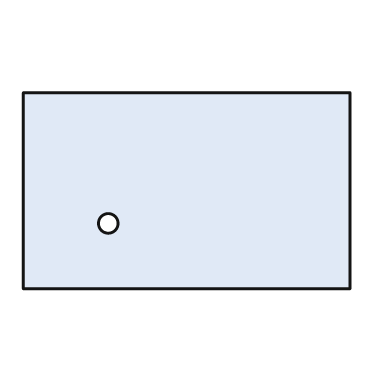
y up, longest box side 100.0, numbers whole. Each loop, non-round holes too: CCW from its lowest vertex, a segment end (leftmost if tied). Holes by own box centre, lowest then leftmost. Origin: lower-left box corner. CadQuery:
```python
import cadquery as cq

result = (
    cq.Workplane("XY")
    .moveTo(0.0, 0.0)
    .lineTo(100.0, 0.0)
    .lineTo(100.0, 60.0)
    .lineTo(0.0, 60.0)
    .close()
    .moveTo(26.0, 20.0)
    .circle(3.0)
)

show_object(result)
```